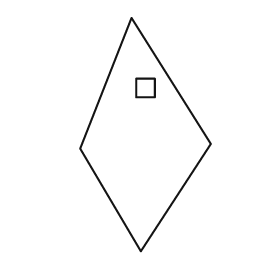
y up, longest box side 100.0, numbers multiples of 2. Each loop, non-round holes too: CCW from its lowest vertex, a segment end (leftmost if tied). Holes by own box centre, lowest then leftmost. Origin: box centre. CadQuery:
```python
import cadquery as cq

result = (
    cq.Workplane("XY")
    .moveTo(-2.0, -50.0)
    .lineTo(28.0, -4.0)
    .lineTo(-6.0, 50.0)
    .lineTo(-28.0, -6.0)
    .close()
    .moveTo(-4.0, 16.0)
    .lineTo(4.0, 16.0)
    .lineTo(4.0, 24.0)
    .lineTo(-4.0, 24.0)
    .close()
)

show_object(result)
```